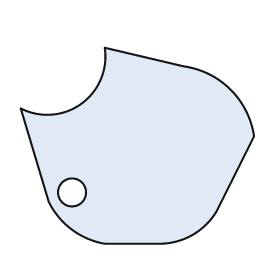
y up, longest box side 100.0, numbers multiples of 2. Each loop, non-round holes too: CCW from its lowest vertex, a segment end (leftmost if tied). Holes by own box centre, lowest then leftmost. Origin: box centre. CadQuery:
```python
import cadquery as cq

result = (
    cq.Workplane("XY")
    .moveTo(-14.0, -42.0)
    .lineTo(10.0, -42.0)
    .threePointArc((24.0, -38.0), (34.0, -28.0))
    .lineTo(50.0, 4.0)
    .threePointArc((40.0, 24.0), (20.0, 34.0))
    .lineTo(-14.0, 42.0)
    .threePointArc((-24.0, 18.0), (-50.0, 16.0))
    .lineTo(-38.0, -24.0)
    .threePointArc((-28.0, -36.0), (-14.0, -42.0))
    .close()
    .moveTo(-28.0, -20.0)
    .circle(6.0)
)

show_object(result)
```